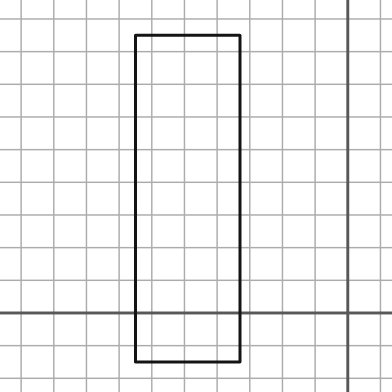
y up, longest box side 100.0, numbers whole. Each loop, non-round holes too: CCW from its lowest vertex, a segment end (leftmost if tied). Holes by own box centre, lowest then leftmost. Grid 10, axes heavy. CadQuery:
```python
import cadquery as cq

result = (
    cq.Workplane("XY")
    .moveTo(-65.0, -15.0)
    .lineTo(-33.0, -15.0)
    .lineTo(-33.0, 85.0)
    .lineTo(-65.0, 85.0)
    .close()
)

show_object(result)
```